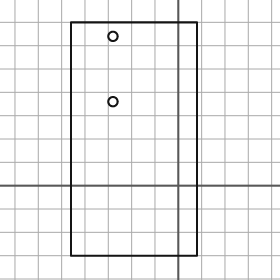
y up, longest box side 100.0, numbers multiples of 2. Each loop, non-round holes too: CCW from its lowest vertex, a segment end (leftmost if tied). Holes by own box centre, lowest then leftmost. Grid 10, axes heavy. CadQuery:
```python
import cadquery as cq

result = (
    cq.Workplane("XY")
    .moveTo(-46.0, -30.0)
    .lineTo(8.0, -30.0)
    .lineTo(8.0, 70.0)
    .lineTo(-46.0, 70.0)
    .close()
    .moveTo(-28.0, 36.0)
    .circle(2.0)
    .moveTo(-28.0, 64.0)
    .circle(2.0)
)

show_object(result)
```